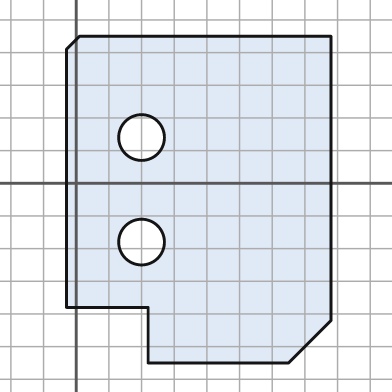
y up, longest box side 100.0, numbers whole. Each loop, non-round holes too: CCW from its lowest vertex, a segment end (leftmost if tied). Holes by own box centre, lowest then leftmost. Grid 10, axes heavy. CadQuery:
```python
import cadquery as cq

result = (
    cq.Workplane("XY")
    .moveTo(22.0, -55.0)
    .lineTo(65.0, -55.0)
    .lineTo(78.0, -42.0)
    .lineTo(78.0, 45.0)
    .lineTo(1.0, 45.0)
    .lineTo(-3.0, 41.0)
    .lineTo(-3.0, -38.0)
    .lineTo(22.0, -38.0)
    .close()
    .moveTo(20.0, -18.0)
    .circle(7.0)
    .moveTo(20.0, 14.0)
    .circle(7.0)
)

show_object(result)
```